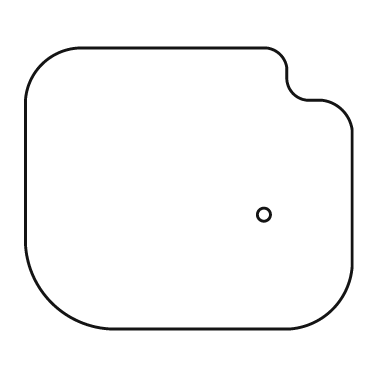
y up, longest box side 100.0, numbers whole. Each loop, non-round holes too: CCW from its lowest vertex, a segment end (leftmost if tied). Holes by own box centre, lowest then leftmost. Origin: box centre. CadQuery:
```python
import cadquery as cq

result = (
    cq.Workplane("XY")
    .moveTo(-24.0, -43.0)
    .lineTo(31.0, -43.0)
    .threePointArc((44.0, -37.0), (50.0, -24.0))
    .lineTo(50.0, 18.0)
    .threePointArc((47.0, 24.0), (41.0, 27.0))
    .lineTo(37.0, 27.0)
    .threePointArc((32.0, 29.0), (30.0, 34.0))
    .lineTo(30.0, 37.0)
    .threePointArc((28.0, 41.0), (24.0, 43.0))
    .lineTo(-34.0, 43.0)
    .threePointArc((-45.0, 38.0), (-50.0, 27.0))
    .lineTo(-50.0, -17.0)
    .threePointArc((-42.0, -35.0), (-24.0, -43.0))
    .close()
    .moveTo(23.0, -8.0)
    .circle(2.0)
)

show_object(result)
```